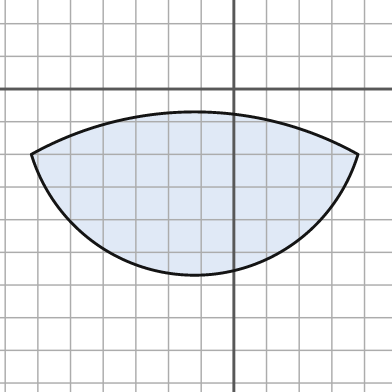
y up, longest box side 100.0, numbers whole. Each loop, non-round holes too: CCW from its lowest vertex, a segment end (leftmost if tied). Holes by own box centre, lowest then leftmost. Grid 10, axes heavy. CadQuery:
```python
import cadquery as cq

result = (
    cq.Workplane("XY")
    .moveTo(-62.0, -20.0)
    .threePointArc((-12.0, -57.0), (38.0, -20.0))
    .threePointArc((-12.0, -7.0), (-62.0, -20.0))
    .close()
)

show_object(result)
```